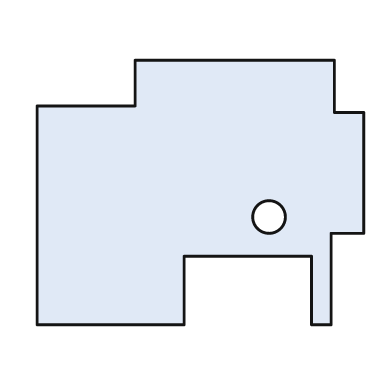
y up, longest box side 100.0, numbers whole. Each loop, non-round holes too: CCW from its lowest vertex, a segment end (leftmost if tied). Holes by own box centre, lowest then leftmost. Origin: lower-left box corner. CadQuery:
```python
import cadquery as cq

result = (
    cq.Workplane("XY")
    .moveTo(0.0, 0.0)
    .lineTo(45.0, 0.0)
    .lineTo(45.0, 21.0)
    .lineTo(84.0, 21.0)
    .lineTo(84.0, 0.0)
    .lineTo(90.0, 0.0)
    .lineTo(90.0, 28.0)
    .lineTo(100.0, 28.0)
    .lineTo(100.0, 65.0)
    .lineTo(91.0, 65.0)
    .lineTo(91.0, 81.0)
    .lineTo(30.0, 81.0)
    .lineTo(30.0, 67.0)
    .lineTo(0.0, 67.0)
    .close()
    .moveTo(71.0, 33.0)
    .circle(5.0)
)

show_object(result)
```